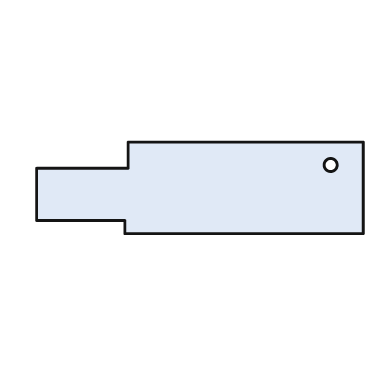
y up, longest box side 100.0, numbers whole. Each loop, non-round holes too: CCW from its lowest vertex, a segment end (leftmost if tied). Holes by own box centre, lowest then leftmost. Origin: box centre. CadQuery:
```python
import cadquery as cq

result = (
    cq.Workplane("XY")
    .moveTo(-23.0, -14.0)
    .lineTo(50.0, -14.0)
    .lineTo(50.0, 14.0)
    .lineTo(-22.0, 14.0)
    .lineTo(-22.0, 6.0)
    .lineTo(-50.0, 6.0)
    .lineTo(-50.0, -10.0)
    .lineTo(-23.0, -10.0)
    .close()
    .moveTo(40.0, 7.0)
    .circle(2.0)
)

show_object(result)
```